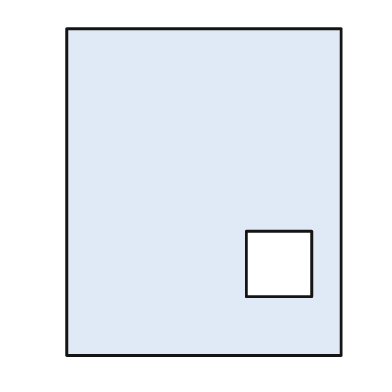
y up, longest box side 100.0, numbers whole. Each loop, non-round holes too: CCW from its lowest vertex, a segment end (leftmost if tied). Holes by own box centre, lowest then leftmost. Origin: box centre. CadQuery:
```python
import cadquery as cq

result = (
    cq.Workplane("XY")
    .moveTo(-42.0, -50.0)
    .lineTo(42.0, -50.0)
    .lineTo(42.0, 50.0)
    .lineTo(-42.0, 50.0)
    .close()
    .moveTo(13.0, -32.0)
    .lineTo(33.0, -32.0)
    .lineTo(33.0, -12.0)
    .lineTo(13.0, -12.0)
    .close()
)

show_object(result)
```